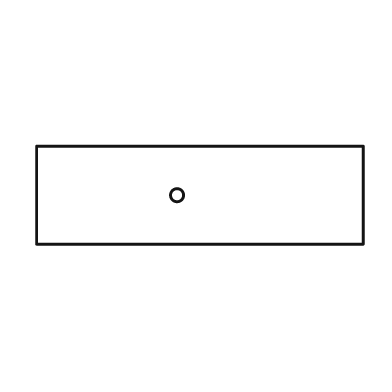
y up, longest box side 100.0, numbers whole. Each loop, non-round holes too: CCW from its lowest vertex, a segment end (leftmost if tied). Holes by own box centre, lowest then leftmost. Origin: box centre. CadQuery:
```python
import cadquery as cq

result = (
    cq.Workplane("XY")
    .moveTo(-50.0, -15.0)
    .lineTo(50.0, -15.0)
    .lineTo(50.0, 15.0)
    .lineTo(-50.0, 15.0)
    .close()
    .moveTo(-7.0, 0.0)
    .circle(2.0)
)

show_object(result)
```